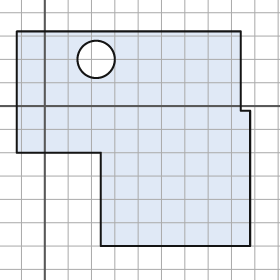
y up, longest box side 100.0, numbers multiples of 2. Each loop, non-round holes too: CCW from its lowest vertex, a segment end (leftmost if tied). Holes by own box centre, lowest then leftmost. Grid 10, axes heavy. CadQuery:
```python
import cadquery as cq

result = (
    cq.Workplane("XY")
    .moveTo(24.0, -60.0)
    .lineTo(88.0, -60.0)
    .lineTo(88.0, -2.0)
    .lineTo(84.0, -2.0)
    .lineTo(84.0, 32.0)
    .lineTo(-12.0, 32.0)
    .lineTo(-12.0, -20.0)
    .lineTo(24.0, -20.0)
    .close()
    .moveTo(22.0, 20.0)
    .circle(8.0)
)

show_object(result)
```